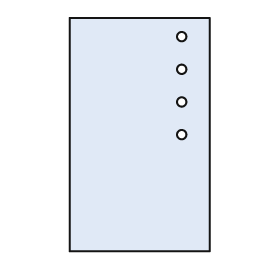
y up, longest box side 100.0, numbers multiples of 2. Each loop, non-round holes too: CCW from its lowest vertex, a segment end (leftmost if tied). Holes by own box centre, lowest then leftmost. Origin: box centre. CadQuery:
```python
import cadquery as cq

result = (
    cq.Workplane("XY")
    .moveTo(-30.0, -50.0)
    .lineTo(30.0, -50.0)
    .lineTo(30.0, 50.0)
    .lineTo(-30.0, 50.0)
    .close()
    .moveTo(18.0, 0.0)
    .circle(2.0)
    .moveTo(18.0, 14.0)
    .circle(2.0)
    .moveTo(18.0, 28.0)
    .circle(2.0)
    .moveTo(18.0, 42.0)
    .circle(2.0)
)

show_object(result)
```